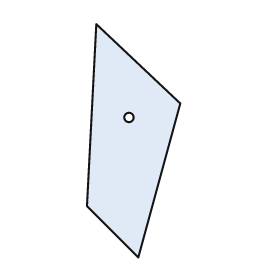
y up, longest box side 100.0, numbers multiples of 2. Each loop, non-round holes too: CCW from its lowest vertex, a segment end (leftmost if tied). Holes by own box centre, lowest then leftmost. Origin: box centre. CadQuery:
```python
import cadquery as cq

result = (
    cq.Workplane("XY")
    .moveTo(2.0, -50.0)
    .lineTo(20.0, 16.0)
    .lineTo(-16.0, 50.0)
    .lineTo(-20.0, -28.0)
    .close()
    .moveTo(-2.0, 10.0)
    .circle(2.0)
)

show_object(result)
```